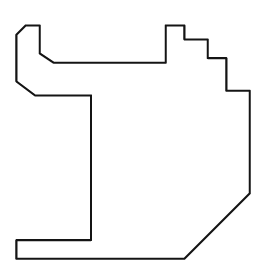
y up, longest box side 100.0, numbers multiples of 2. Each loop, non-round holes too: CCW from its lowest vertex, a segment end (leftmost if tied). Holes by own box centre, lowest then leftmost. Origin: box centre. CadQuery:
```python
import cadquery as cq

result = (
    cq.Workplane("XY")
    .moveTo(-50.0, -50.0)
    .lineTo(22.0, -50.0)
    .lineTo(50.0, -22.0)
    .lineTo(50.0, 22.0)
    .lineTo(40.0, 22.0)
    .lineTo(40.0, 36.0)
    .lineTo(32.0, 36.0)
    .lineTo(32.0, 44.0)
    .lineTo(22.0, 44.0)
    .lineTo(22.0, 50.0)
    .lineTo(14.0, 50.0)
    .lineTo(14.0, 34.0)
    .lineTo(-34.0, 34.0)
    .lineTo(-40.0, 38.0)
    .lineTo(-40.0, 50.0)
    .lineTo(-46.0, 50.0)
    .lineTo(-50.0, 46.0)
    .lineTo(-50.0, 26.0)
    .lineTo(-42.0, 20.0)
    .lineTo(-18.0, 20.0)
    .lineTo(-18.0, -42.0)
    .lineTo(-50.0, -42.0)
    .close()
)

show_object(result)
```